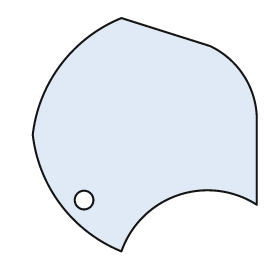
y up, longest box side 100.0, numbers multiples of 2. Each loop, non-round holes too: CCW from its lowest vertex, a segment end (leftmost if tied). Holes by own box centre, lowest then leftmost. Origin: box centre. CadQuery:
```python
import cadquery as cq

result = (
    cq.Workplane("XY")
    .moveTo(-10.0, -50.0)
    .threePointArc((14.0, -26.0), (48.0, -30.0))
    .lineTo(48.0, 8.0)
    .threePointArc((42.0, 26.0), (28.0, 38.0))
    .lineTo(-10.0, 50.0)
    .threePointArc((-36.0, 30.0), (-48.0, 0.0))
    .threePointArc((-36.0, -30.0), (-10.0, -50.0))
    .close()
    .moveTo(-26.0, -28.0)
    .circle(4.0)
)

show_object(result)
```